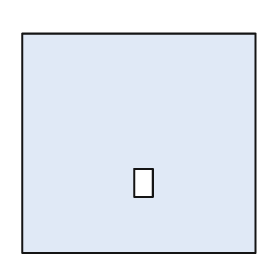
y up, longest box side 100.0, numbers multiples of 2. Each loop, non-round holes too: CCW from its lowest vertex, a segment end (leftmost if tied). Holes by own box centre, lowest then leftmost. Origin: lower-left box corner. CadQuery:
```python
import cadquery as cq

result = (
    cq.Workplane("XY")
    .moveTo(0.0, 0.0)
    .lineTo(100.0, 0.0)
    .lineTo(100.0, 94.0)
    .lineTo(0.0, 94.0)
    .close()
    .moveTo(48.0, 24.0)
    .lineTo(56.0, 24.0)
    .lineTo(56.0, 36.0)
    .lineTo(48.0, 36.0)
    .close()
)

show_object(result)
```